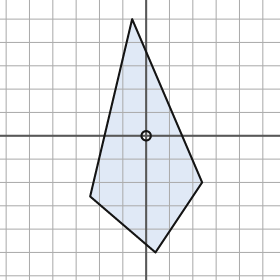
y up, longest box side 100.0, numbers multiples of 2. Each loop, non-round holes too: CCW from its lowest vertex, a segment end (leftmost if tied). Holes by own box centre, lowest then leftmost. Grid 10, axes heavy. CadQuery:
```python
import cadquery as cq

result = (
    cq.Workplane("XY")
    .moveTo(4.0, -50.0)
    .lineTo(24.0, -20.0)
    .lineTo(-6.0, 50.0)
    .lineTo(-24.0, -26.0)
    .close()
    .moveTo(0.0, 0.0)
    .circle(2.0)
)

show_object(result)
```